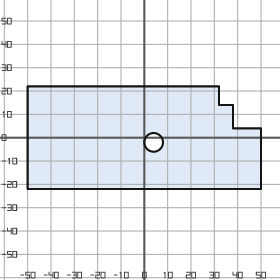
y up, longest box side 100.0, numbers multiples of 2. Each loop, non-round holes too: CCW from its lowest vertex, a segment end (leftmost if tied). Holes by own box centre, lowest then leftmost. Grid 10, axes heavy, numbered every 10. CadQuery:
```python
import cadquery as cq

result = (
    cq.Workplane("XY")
    .moveTo(-50.0, -22.0)
    .lineTo(50.0, -22.0)
    .lineTo(50.0, 4.0)
    .lineTo(38.0, 4.0)
    .lineTo(38.0, 14.0)
    .lineTo(32.0, 14.0)
    .lineTo(32.0, 22.0)
    .lineTo(-50.0, 22.0)
    .close()
    .moveTo(4.0, -2.0)
    .circle(4.0)
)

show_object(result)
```